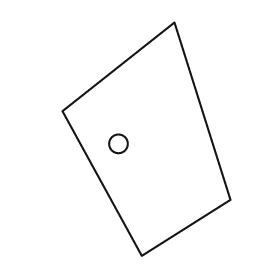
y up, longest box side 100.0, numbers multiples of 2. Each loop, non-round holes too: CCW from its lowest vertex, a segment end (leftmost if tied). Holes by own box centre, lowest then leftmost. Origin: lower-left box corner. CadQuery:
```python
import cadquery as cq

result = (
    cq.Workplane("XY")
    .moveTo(34.0, 0.0)
    .lineTo(72.0, 24.0)
    .lineTo(48.0, 100.0)
    .lineTo(0.0, 62.0)
    .close()
    .moveTo(24.0, 48.0)
    .circle(4.0)
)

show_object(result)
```